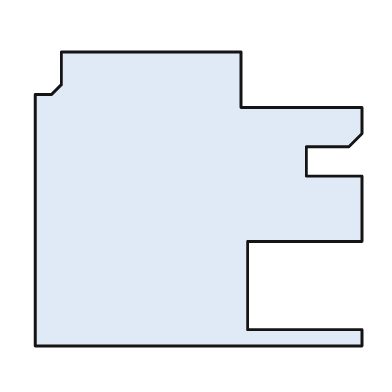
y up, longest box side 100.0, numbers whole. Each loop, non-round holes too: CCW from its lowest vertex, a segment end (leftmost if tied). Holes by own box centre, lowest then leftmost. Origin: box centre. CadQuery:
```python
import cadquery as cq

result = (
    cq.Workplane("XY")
    .moveTo(-50.0, -45.0)
    .lineTo(50.0, -45.0)
    .lineTo(50.0, -40.0)
    .lineTo(15.0, -40.0)
    .lineTo(15.0, -13.0)
    .lineTo(50.0, -13.0)
    .lineTo(50.0, 7.0)
    .lineTo(33.0, 7.0)
    .lineTo(33.0, 16.0)
    .lineTo(46.0, 16.0)
    .lineTo(50.0, 20.0)
    .lineTo(50.0, 28.0)
    .lineTo(13.0, 28.0)
    .lineTo(13.0, 45.0)
    .lineTo(-42.0, 45.0)
    .lineTo(-42.0, 35.0)
    .lineTo(-45.0, 32.0)
    .lineTo(-50.0, 32.0)
    .close()
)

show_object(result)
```